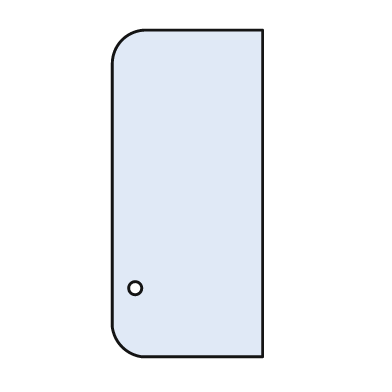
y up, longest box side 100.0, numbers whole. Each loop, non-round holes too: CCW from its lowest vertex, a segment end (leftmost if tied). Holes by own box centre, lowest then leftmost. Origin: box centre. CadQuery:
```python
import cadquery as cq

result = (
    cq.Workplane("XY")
    .moveTo(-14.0, -50.0)
    .lineTo(23.0, -50.0)
    .lineTo(23.0, 50.0)
    .lineTo(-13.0, 50.0)
    .threePointArc((-20.0, 47.0), (-23.0, 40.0))
    .lineTo(-23.0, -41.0)
    .threePointArc((-20.0, -47.0), (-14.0, -50.0))
    .close()
    .moveTo(-16.0, -29.0)
    .circle(2.0)
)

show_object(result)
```